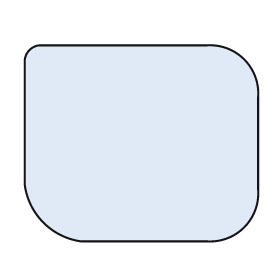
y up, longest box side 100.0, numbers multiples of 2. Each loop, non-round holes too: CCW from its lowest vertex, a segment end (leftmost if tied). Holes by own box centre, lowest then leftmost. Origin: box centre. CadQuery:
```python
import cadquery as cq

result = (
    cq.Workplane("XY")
    .moveTo(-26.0, -42.0)
    .lineTo(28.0, -42.0)
    .threePointArc((44.0, -36.0), (50.0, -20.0))
    .lineTo(50.0, 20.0)
    .threePointArc((44.0, 36.0), (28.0, 42.0))
    .lineTo(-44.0, 42.0)
    .threePointArc((-48.0, 40.0), (-50.0, 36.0))
    .lineTo(-50.0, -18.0)
    .threePointArc((-42.0, -34.0), (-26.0, -42.0))
    .close()
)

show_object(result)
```